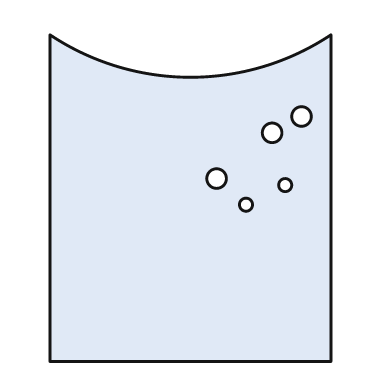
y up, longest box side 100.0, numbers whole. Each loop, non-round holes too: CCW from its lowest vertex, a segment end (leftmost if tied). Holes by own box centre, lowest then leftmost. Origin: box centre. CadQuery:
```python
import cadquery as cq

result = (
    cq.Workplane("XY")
    .moveTo(-43.0, -50.0)
    .lineTo(43.0, -50.0)
    .lineTo(43.0, 50.0)
    .threePointArc((0.0, 37.0), (-43.0, 50.0))
    .close()
    .moveTo(17.0, -2.0)
    .circle(2.0)
    .moveTo(29.0, 4.0)
    .circle(2.0)
    .moveTo(8.0, 6.0)
    .circle(3.0)
    .moveTo(25.0, 20.0)
    .circle(3.0)
    .moveTo(34.0, 25.0)
    .circle(3.0)
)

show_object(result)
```